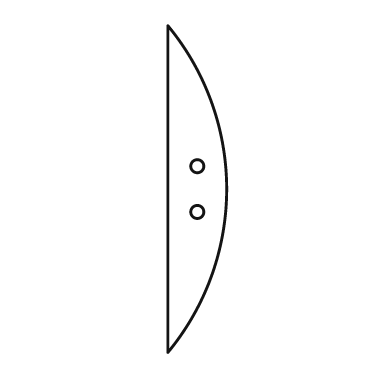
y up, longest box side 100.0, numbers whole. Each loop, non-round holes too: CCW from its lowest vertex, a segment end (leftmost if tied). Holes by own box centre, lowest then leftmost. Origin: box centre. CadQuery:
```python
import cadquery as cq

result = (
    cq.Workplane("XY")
    .moveTo(-9.0, -50.0)
    .threePointArc((9.0, 0.0), (-9.0, 50.0))
    .close()
    .moveTo(0.0, -7.0)
    .circle(2.0)
    .moveTo(0.0, 7.0)
    .circle(2.0)
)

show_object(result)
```